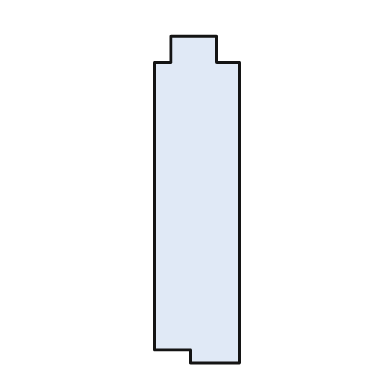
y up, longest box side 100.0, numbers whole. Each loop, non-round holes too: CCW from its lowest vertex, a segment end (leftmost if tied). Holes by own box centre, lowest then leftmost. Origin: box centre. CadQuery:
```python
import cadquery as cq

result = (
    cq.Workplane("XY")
    .moveTo(-2.0, -50.0)
    .lineTo(13.0, -50.0)
    .lineTo(13.0, 42.0)
    .lineTo(6.0, 42.0)
    .lineTo(6.0, 50.0)
    .lineTo(-8.0, 50.0)
    .lineTo(-8.0, 42.0)
    .lineTo(-13.0, 42.0)
    .lineTo(-13.0, -46.0)
    .lineTo(-2.0, -46.0)
    .close()
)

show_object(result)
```